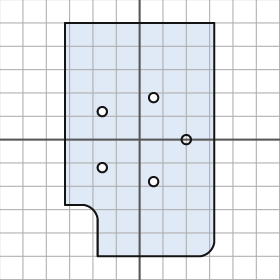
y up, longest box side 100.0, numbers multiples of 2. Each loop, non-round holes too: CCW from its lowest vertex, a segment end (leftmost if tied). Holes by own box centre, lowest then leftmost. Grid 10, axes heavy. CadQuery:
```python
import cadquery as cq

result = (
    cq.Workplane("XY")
    .moveTo(-18.0, -50.0)
    .lineTo(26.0, -50.0)
    .threePointArc((30.0, -48.0), (32.0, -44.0))
    .lineTo(32.0, 50.0)
    .lineTo(-32.0, 50.0)
    .lineTo(-32.0, -28.0)
    .lineTo(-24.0, -28.0)
    .threePointArc((-20.0, -30.0), (-18.0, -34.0))
    .close()
    .moveTo(6.0, -18.0)
    .circle(2.0)
    .moveTo(-16.0, -12.0)
    .circle(2.0)
    .moveTo(20.0, 0.0)
    .circle(2.0)
    .moveTo(-16.0, 12.0)
    .circle(2.0)
    .moveTo(6.0, 18.0)
    .circle(2.0)
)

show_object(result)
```